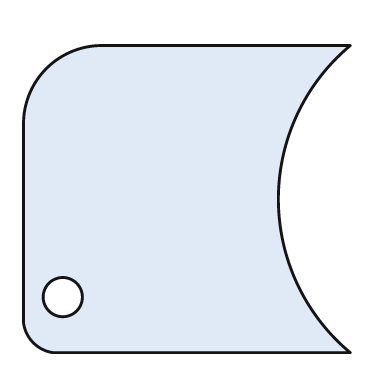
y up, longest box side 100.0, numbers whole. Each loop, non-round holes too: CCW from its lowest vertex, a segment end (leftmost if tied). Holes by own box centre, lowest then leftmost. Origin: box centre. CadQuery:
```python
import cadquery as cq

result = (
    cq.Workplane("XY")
    .moveTo(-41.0, -47.0)
    .lineTo(50.0, -47.0)
    .threePointArc((28.0, 0.0), (50.0, 47.0))
    .lineTo(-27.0, 47.0)
    .threePointArc((-43.0, 40.0), (-50.0, 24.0))
    .lineTo(-50.0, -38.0)
    .threePointArc((-47.0, -44.0), (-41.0, -47.0))
    .close()
    .moveTo(-38.0, -30.0)
    .circle(6.0)
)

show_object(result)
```